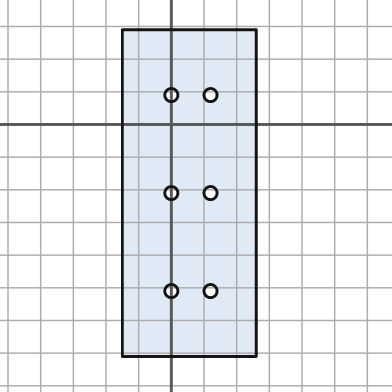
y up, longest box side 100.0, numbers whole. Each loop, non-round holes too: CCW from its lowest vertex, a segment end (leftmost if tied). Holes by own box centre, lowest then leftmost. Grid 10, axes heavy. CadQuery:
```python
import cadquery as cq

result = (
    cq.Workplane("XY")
    .moveTo(-15.0, -71.0)
    .lineTo(26.0, -71.0)
    .lineTo(26.0, 29.0)
    .lineTo(-15.0, 29.0)
    .close()
    .moveTo(0.0, -51.0)
    .circle(2.0)
    .moveTo(12.0, -51.0)
    .circle(2.0)
    .moveTo(0.0, -21.0)
    .circle(2.0)
    .moveTo(12.0, -21.0)
    .circle(2.0)
    .moveTo(0.0, 9.0)
    .circle(2.0)
    .moveTo(12.0, 9.0)
    .circle(2.0)
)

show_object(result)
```